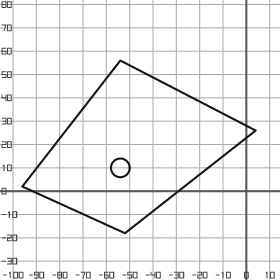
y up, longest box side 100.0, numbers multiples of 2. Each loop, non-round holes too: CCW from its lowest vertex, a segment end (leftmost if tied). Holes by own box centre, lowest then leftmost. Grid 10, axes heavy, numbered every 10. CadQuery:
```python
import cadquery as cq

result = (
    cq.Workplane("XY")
    .moveTo(-52.0, -18.0)
    .lineTo(4.0, 26.0)
    .lineTo(-54.0, 56.0)
    .lineTo(-96.0, 2.0)
    .close()
    .moveTo(-54.0, 10.0)
    .circle(4.0)
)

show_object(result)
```